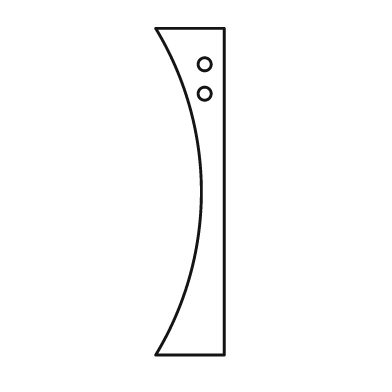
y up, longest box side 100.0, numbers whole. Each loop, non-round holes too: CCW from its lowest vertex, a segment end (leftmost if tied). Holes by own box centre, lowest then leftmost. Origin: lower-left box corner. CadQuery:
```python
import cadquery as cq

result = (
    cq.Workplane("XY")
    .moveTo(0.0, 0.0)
    .lineTo(21.0, 0.0)
    .lineTo(21.0, 100.0)
    .lineTo(0.0, 100.0)
    .threePointArc((14.0, 50.0), (0.0, 0.0))
    .close()
    .moveTo(15.0, 80.0)
    .circle(2.0)
    .moveTo(15.0, 89.0)
    .circle(2.0)
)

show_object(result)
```